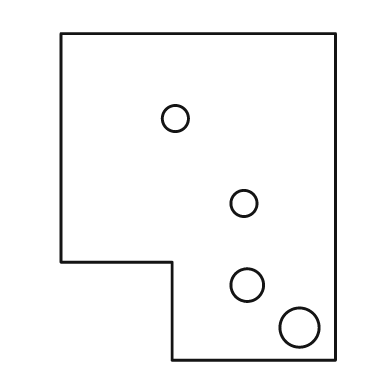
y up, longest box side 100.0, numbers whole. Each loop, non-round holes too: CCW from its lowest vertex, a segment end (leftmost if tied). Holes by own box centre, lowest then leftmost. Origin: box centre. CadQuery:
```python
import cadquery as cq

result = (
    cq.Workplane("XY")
    .moveTo(-8.0, -50.0)
    .lineTo(42.0, -50.0)
    .lineTo(42.0, 50.0)
    .lineTo(-42.0, 50.0)
    .lineTo(-42.0, -20.0)
    .lineTo(-8.0, -20.0)
    .close()
    .moveTo(31.0, -40.0)
    .circle(6.0)
    .moveTo(15.0, -27.0)
    .circle(5.0)
    .moveTo(14.0, -2.0)
    .circle(4.0)
    .moveTo(-7.0, 24.0)
    .circle(4.0)
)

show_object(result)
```